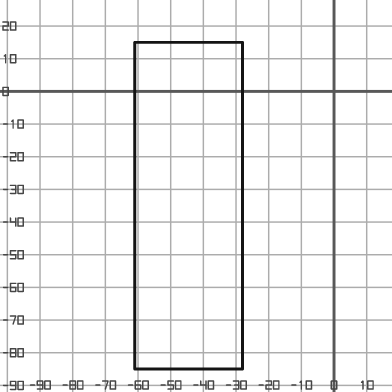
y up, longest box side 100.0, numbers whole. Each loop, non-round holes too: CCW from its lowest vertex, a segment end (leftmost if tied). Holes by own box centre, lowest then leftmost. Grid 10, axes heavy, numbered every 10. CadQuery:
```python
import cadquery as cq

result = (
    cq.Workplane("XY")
    .moveTo(-61.0, -85.0)
    .lineTo(-28.0, -85.0)
    .lineTo(-28.0, 15.0)
    .lineTo(-61.0, 15.0)
    .close()
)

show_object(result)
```